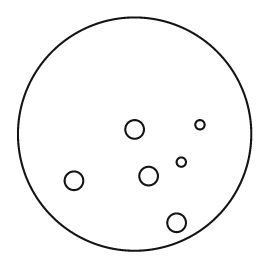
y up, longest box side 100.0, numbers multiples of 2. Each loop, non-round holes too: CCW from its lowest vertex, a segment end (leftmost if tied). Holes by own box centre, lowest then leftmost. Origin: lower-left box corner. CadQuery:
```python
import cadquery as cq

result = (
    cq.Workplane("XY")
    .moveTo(50.0, 50.0)
    .circle(50.0)
    .moveTo(68.0, 12.0)
    .circle(4.0)
    .moveTo(24.0, 30.0)
    .circle(4.0)
    .moveTo(56.0, 32.0)
    .circle(4.0)
    .moveTo(70.0, 38.0)
    .circle(2.0)
    .moveTo(50.0, 52.0)
    .circle(4.0)
    .moveTo(78.0, 54.0)
    .circle(2.0)
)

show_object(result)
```